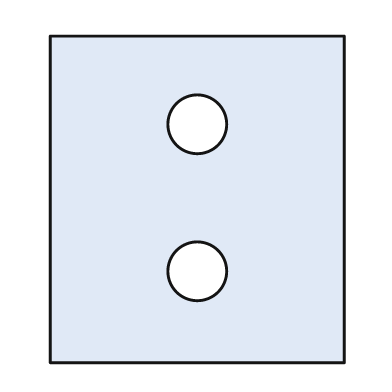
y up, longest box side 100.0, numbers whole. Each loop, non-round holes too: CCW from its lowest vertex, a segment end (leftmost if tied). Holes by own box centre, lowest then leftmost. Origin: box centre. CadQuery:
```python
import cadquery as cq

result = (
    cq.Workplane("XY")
    .moveTo(-45.0, -50.0)
    .lineTo(45.0, -50.0)
    .lineTo(45.0, 50.0)
    .lineTo(-45.0, 50.0)
    .close()
    .moveTo(0.0, -22.0)
    .circle(9.0)
    .moveTo(0.0, 23.0)
    .circle(9.0)
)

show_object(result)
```